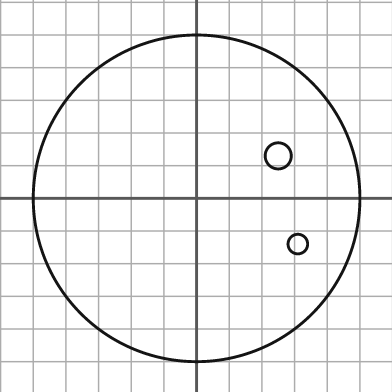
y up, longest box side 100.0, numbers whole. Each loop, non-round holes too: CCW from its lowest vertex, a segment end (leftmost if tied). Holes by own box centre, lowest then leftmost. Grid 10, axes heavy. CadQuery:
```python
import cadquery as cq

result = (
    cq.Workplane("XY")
    .moveTo(0.0, 0.0)
    .circle(50.0)
    .moveTo(31.0, -14.0)
    .circle(3.0)
    .moveTo(25.0, 13.0)
    .circle(4.0)
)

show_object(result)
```